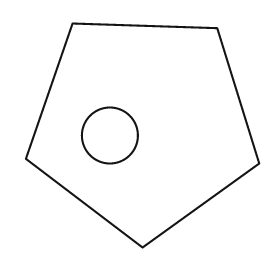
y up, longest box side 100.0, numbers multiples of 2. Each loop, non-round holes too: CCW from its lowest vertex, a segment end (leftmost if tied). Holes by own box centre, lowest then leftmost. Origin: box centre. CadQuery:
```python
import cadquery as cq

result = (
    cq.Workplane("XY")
    .moveTo(0.0, -48.0)
    .lineTo(50.0, -12.0)
    .lineTo(32.0, 46.0)
    .lineTo(-30.0, 48.0)
    .lineTo(-50.0, -10.0)
    .close()
    .moveTo(-14.0, 0.0)
    .circle(12.0)
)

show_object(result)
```